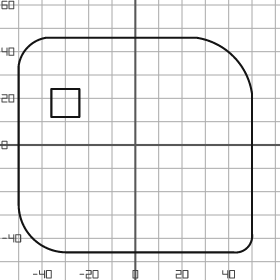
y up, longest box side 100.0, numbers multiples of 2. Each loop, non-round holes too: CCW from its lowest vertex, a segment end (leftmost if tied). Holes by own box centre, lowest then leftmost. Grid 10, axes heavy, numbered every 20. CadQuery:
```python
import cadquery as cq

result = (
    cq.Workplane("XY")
    .moveTo(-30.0, -46.0)
    .lineTo(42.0, -46.0)
    .threePointArc((48.0, -44.0), (50.0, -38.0))
    .lineTo(50.0, 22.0)
    .threePointArc((42.0, 38.0), (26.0, 46.0))
    .lineTo(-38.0, 46.0)
    .threePointArc((-46.0, 42.0), (-50.0, 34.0))
    .lineTo(-50.0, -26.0)
    .threePointArc((-44.0, -40.0), (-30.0, -46.0))
    .close()
    .moveTo(-36.0, 12.0)
    .lineTo(-24.0, 12.0)
    .lineTo(-24.0, 24.0)
    .lineTo(-36.0, 24.0)
    .close()
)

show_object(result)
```